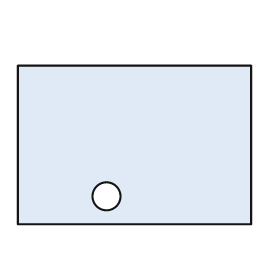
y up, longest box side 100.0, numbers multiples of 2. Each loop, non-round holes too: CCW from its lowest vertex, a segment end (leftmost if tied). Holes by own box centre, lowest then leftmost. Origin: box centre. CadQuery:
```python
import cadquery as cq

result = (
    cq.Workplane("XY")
    .moveTo(-50.0, -34.0)
    .lineTo(50.0, -34.0)
    .lineTo(50.0, 34.0)
    .lineTo(-50.0, 34.0)
    .close()
    .moveTo(-12.0, -22.0)
    .circle(6.0)
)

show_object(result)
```